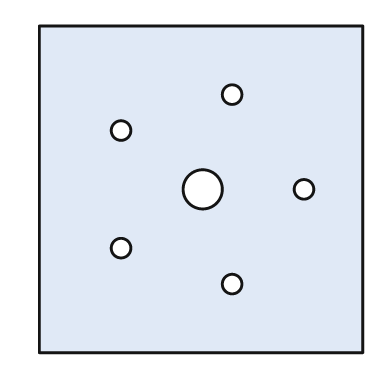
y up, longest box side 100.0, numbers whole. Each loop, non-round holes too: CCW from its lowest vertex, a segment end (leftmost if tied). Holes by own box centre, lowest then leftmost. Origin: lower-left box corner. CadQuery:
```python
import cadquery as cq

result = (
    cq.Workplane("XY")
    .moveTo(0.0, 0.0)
    .lineTo(99.0, 0.0)
    .lineTo(99.0, 100.0)
    .lineTo(0.0, 100.0)
    .close()
    .moveTo(59.0, 21.0)
    .circle(3.0)
    .moveTo(25.0, 32.0)
    .circle(3.0)
    .moveTo(50.0, 50.0)
    .circle(6.0)
    .moveTo(81.0, 50.0)
    .circle(3.0)
    .moveTo(25.0, 68.0)
    .circle(3.0)
    .moveTo(59.0, 79.0)
    .circle(3.0)
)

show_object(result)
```